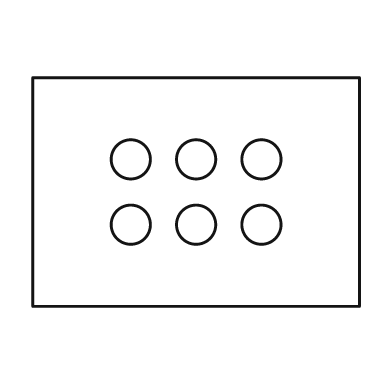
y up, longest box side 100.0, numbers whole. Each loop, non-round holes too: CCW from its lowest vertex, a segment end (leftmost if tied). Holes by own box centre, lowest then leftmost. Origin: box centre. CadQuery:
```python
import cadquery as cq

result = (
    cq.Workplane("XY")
    .moveTo(-50.0, -35.0)
    .lineTo(50.0, -35.0)
    .lineTo(50.0, 35.0)
    .lineTo(-50.0, 35.0)
    .close()
    .moveTo(-20.0, -10.0)
    .circle(6.0)
    .moveTo(0.0, -10.0)
    .circle(6.0)
    .moveTo(20.0, -10.0)
    .circle(6.0)
    .moveTo(-20.0, 10.0)
    .circle(6.0)
    .moveTo(0.0, 10.0)
    .circle(6.0)
    .moveTo(20.0, 10.0)
    .circle(6.0)
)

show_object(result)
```